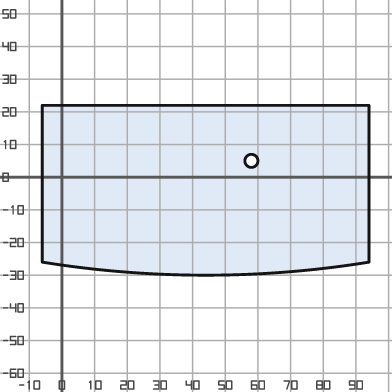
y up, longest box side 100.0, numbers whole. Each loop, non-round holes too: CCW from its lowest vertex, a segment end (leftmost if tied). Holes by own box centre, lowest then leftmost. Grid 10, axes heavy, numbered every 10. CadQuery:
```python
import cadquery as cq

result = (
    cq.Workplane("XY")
    .moveTo(-6.0, -26.0)
    .threePointArc((44.0, -30.0), (94.0, -26.0))
    .lineTo(94.0, 22.0)
    .lineTo(-6.0, 22.0)
    .close()
    .moveTo(58.0, 5.0)
    .circle(2.0)
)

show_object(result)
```